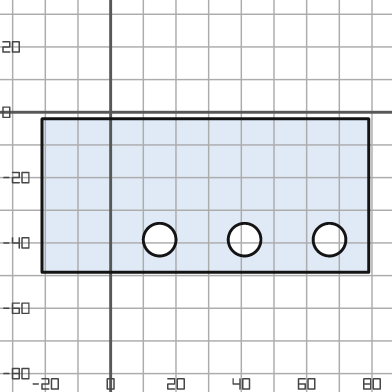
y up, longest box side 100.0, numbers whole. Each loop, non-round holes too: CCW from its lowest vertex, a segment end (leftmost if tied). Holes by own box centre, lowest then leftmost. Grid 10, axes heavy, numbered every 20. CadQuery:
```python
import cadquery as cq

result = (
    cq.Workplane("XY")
    .moveTo(-21.0, -49.0)
    .lineTo(79.0, -49.0)
    .lineTo(79.0, -2.0)
    .lineTo(-21.0, -2.0)
    .close()
    .moveTo(15.0, -39.0)
    .circle(5.0)
    .moveTo(41.0, -39.0)
    .circle(5.0)
    .moveTo(67.0, -39.0)
    .circle(5.0)
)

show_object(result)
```